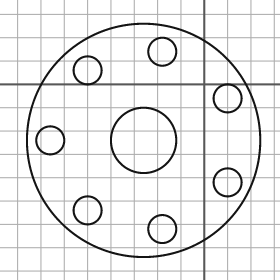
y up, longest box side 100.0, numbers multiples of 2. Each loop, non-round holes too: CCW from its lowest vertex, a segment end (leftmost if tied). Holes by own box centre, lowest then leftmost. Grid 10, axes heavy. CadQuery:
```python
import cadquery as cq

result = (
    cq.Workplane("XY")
    .moveTo(-26.0, -24.0)
    .circle(50.0)
    .moveTo(-18.0, -62.0)
    .circle(6.0)
    .moveTo(-50.0, -54.0)
    .circle(6.0)
    .moveTo(10.0, -42.0)
    .circle(6.0)
    .moveTo(-66.0, -24.0)
    .circle(6.0)
    .moveTo(-26.0, -24.0)
    .circle(14.0)
    .moveTo(10.0, -6.0)
    .circle(6.0)
    .moveTo(-50.0, 6.0)
    .circle(6.0)
    .moveTo(-18.0, 14.0)
    .circle(6.0)
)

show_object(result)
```